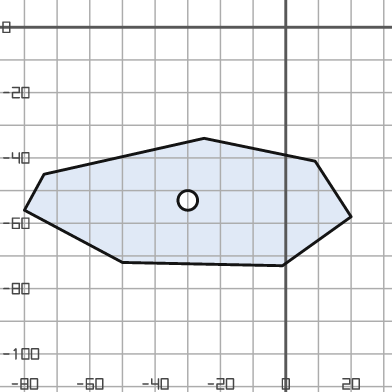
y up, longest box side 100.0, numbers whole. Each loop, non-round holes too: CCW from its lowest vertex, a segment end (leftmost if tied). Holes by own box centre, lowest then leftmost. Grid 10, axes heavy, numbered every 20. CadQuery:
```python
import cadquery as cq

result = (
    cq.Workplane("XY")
    .moveTo(-1.0, -73.0)
    .lineTo(20.0, -58.0)
    .lineTo(9.0, -41.0)
    .lineTo(-25.0, -34.0)
    .lineTo(-74.0, -45.0)
    .lineTo(-80.0, -56.0)
    .lineTo(-50.0, -72.0)
    .close()
    .moveTo(-30.0, -53.0)
    .circle(3.0)
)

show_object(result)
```